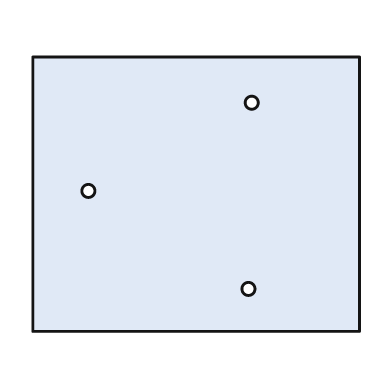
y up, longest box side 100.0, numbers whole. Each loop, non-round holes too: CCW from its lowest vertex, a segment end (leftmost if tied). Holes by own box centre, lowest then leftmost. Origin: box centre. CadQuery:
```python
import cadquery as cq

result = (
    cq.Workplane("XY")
    .moveTo(-50.0, -42.0)
    .lineTo(50.0, -42.0)
    .lineTo(50.0, 42.0)
    .lineTo(-50.0, 42.0)
    .close()
    .moveTo(16.0, -29.0)
    .circle(2.0)
    .moveTo(-33.0, 1.0)
    .circle(2.0)
    .moveTo(17.0, 28.0)
    .circle(2.0)
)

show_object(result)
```